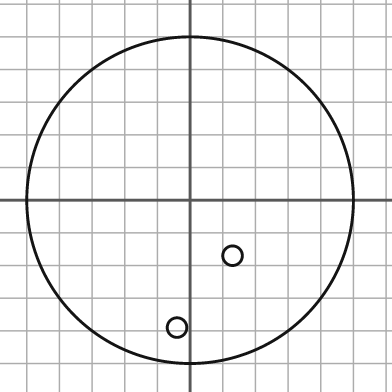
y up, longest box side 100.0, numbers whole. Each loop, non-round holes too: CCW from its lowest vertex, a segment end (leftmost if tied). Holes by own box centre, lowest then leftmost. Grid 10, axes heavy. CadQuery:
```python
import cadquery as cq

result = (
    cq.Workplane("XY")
    .moveTo(0.0, 0.0)
    .circle(50.0)
    .moveTo(-4.0, -39.0)
    .circle(3.0)
    .moveTo(13.0, -17.0)
    .circle(3.0)
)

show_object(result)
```